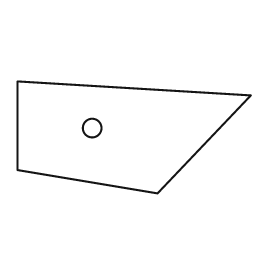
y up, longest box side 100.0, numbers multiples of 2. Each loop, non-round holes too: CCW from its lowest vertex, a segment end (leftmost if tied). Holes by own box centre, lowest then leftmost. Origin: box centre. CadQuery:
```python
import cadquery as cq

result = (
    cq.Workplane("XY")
    .moveTo(10.0, -24.0)
    .lineTo(50.0, 18.0)
    .lineTo(-50.0, 24.0)
    .lineTo(-50.0, -14.0)
    .close()
    .moveTo(-18.0, 4.0)
    .circle(4.0)
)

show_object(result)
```